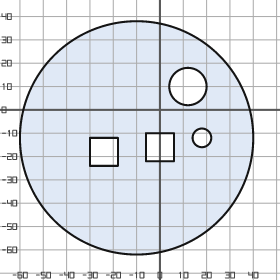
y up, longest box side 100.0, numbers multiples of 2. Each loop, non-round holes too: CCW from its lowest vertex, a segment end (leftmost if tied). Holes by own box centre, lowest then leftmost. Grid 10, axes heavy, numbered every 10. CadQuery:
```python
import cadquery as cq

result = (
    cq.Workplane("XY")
    .moveTo(-10.0, -12.0)
    .circle(50.0)
    .moveTo(-30.0, -24.0)
    .lineTo(-18.0, -24.0)
    .lineTo(-18.0, -12.0)
    .lineTo(-30.0, -12.0)
    .close()
    .moveTo(-6.0, -22.0)
    .lineTo(6.0, -22.0)
    .lineTo(6.0, -10.0)
    .lineTo(-6.0, -10.0)
    .close()
    .moveTo(18.0, -12.0)
    .circle(4.0)
    .moveTo(12.0, 10.0)
    .circle(8.0)
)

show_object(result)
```